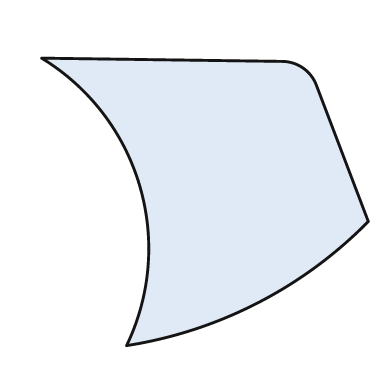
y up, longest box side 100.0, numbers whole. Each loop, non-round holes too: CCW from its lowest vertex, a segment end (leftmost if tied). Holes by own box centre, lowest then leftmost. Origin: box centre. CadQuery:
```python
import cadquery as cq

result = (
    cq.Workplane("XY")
    .moveTo(-24.0, -44.0)
    .threePointArc((16.0, -31.0), (50.0, -6.0))
    .lineTo(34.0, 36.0)
    .threePointArc((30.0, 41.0), (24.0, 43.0))
    .lineTo(-50.0, 44.0)
    .threePointArc((-20.0, 5.0), (-24.0, -44.0))
    .close()
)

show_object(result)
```